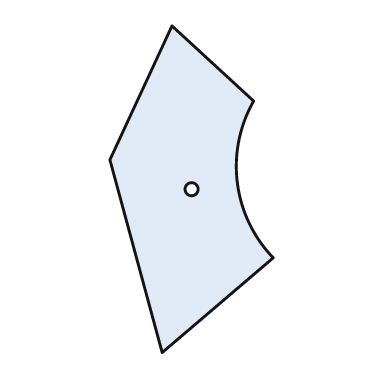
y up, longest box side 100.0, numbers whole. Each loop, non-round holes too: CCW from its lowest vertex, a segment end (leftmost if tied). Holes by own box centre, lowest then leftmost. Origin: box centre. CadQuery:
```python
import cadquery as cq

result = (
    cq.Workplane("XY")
    .moveTo(-9.0, -50.0)
    .lineTo(25.0, -21.0)
    .threePointArc((14.0, 2.0), (19.0, 27.0))
    .lineTo(-6.0, 50.0)
    .lineTo(-25.0, 9.0)
    .close()
    .moveTo(0.0, 0.0)
    .circle(2.0)
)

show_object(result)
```